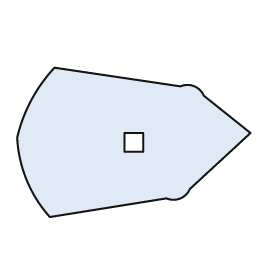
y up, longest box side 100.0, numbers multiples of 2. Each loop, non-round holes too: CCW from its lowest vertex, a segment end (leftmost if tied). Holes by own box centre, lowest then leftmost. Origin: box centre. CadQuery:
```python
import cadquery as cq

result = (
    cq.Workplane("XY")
    .moveTo(-36.0, -32.0)
    .lineTo(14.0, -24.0)
    .threePointArc((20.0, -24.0), (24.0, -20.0))
    .lineTo(50.0, 4.0)
    .lineTo(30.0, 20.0)
    .threePointArc((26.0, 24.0), (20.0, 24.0))
    .lineTo(-34.0, 32.0)
    .threePointArc((-44.0, 18.0), (-50.0, 2.0))
    .threePointArc((-46.0, -16.0), (-36.0, -32.0))
    .close()
    .moveTo(-4.0, -4.0)
    .lineTo(4.0, -4.0)
    .lineTo(4.0, 4.0)
    .lineTo(-4.0, 4.0)
    .close()
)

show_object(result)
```